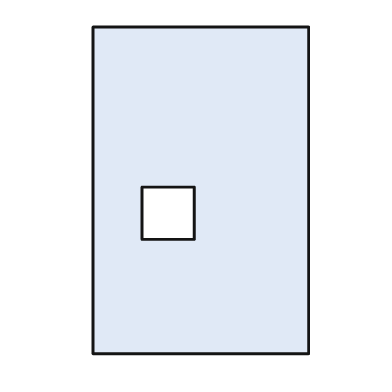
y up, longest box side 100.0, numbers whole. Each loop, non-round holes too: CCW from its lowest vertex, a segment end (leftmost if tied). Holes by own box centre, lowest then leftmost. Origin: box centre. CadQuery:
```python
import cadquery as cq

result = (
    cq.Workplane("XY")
    .moveTo(-33.0, -50.0)
    .lineTo(33.0, -50.0)
    .lineTo(33.0, 50.0)
    .lineTo(-33.0, 50.0)
    .close()
    .moveTo(-18.0, -15.0)
    .lineTo(-2.0, -15.0)
    .lineTo(-2.0, 1.0)
    .lineTo(-18.0, 1.0)
    .close()
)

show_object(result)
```